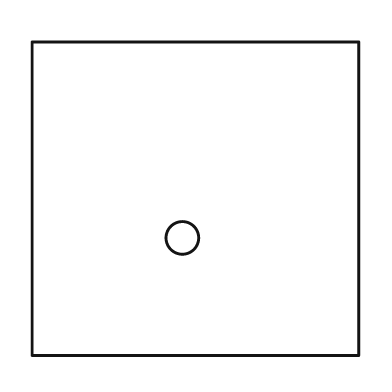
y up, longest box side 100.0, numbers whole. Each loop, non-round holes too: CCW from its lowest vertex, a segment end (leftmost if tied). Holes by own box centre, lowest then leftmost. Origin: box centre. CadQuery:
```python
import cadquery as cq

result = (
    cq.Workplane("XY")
    .moveTo(-50.0, -48.0)
    .lineTo(50.0, -48.0)
    .lineTo(50.0, 48.0)
    .lineTo(-50.0, 48.0)
    .close()
    .moveTo(-4.0, -12.0)
    .circle(5.0)
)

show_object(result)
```